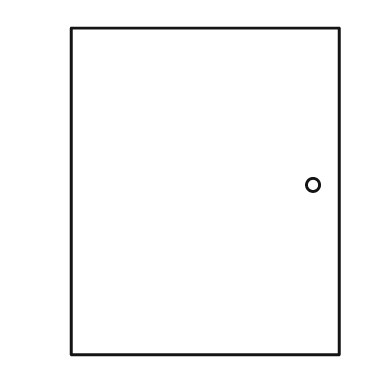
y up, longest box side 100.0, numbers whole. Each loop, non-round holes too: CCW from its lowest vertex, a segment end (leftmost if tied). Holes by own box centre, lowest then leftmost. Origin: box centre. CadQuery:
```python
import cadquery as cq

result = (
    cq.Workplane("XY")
    .moveTo(-41.0, -50.0)
    .lineTo(41.0, -50.0)
    .lineTo(41.0, 50.0)
    .lineTo(-41.0, 50.0)
    .close()
    .moveTo(33.0, 2.0)
    .circle(2.0)
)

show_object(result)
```